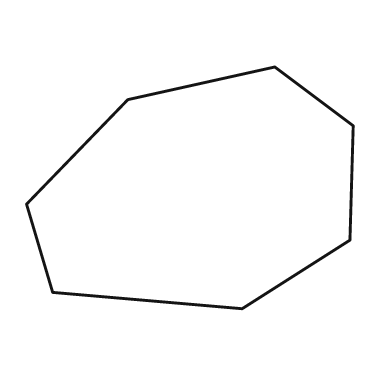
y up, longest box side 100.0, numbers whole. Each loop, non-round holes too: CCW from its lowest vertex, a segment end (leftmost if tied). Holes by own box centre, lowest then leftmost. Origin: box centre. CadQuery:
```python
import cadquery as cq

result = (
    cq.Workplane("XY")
    .moveTo(16.0, -37.0)
    .lineTo(49.0, -16.0)
    .lineTo(50.0, 19.0)
    .lineTo(26.0, 37.0)
    .lineTo(-19.0, 27.0)
    .lineTo(-50.0, -5.0)
    .lineTo(-42.0, -32.0)
    .close()
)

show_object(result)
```